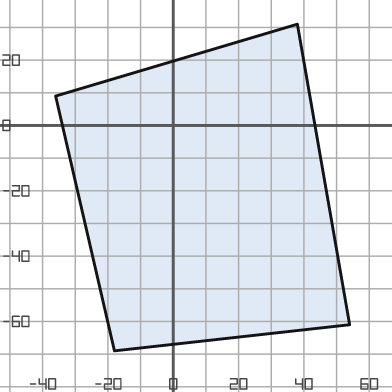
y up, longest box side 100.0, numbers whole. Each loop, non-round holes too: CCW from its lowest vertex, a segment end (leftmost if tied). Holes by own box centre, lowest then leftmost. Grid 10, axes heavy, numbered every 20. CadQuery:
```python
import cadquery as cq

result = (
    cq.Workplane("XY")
    .moveTo(-18.0, -69.0)
    .lineTo(54.0, -61.0)
    .lineTo(38.0, 31.0)
    .lineTo(-36.0, 9.0)
    .close()
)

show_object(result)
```